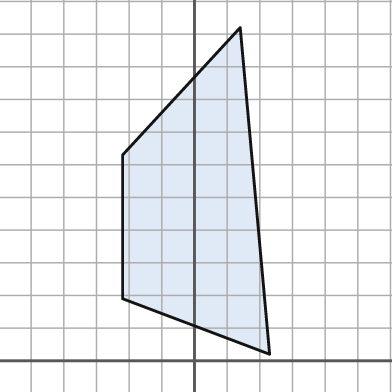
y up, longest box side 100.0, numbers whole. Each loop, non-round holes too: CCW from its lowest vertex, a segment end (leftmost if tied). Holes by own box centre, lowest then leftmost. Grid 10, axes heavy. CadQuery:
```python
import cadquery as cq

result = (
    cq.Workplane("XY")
    .moveTo(23.0, 2.0)
    .lineTo(14.0, 102.0)
    .lineTo(-22.0, 63.0)
    .lineTo(-22.0, 19.0)
    .close()
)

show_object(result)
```